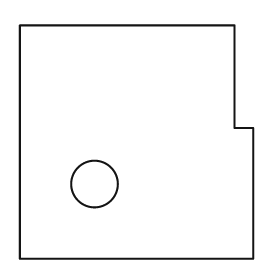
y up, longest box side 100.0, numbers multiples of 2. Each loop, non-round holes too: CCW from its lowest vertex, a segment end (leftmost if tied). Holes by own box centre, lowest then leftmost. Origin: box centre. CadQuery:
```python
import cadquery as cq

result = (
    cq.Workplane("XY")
    .moveTo(-50.0, -50.0)
    .lineTo(50.0, -50.0)
    .lineTo(50.0, 6.0)
    .lineTo(42.0, 6.0)
    .lineTo(42.0, 50.0)
    .lineTo(-50.0, 50.0)
    .close()
    .moveTo(-18.0, -18.0)
    .circle(10.0)
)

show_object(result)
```